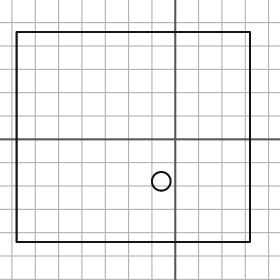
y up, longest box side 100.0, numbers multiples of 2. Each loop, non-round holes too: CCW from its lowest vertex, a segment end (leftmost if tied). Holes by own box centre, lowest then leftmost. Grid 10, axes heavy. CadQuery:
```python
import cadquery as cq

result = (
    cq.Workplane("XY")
    .moveTo(-68.0, -44.0)
    .lineTo(32.0, -44.0)
    .lineTo(32.0, 46.0)
    .lineTo(-68.0, 46.0)
    .close()
    .moveTo(-6.0, -18.0)
    .circle(4.0)
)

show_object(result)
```